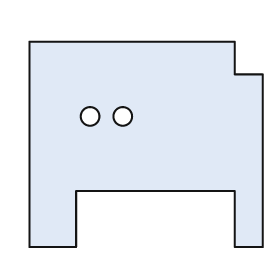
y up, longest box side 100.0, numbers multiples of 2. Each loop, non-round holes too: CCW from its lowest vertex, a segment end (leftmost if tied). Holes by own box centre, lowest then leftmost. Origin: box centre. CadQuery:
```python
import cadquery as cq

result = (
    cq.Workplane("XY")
    .moveTo(-50.0, -44.0)
    .lineTo(-30.0, -44.0)
    .lineTo(-30.0, -20.0)
    .lineTo(38.0, -20.0)
    .lineTo(38.0, -44.0)
    .lineTo(50.0, -44.0)
    .lineTo(50.0, 30.0)
    .lineTo(38.0, 30.0)
    .lineTo(38.0, 44.0)
    .lineTo(-50.0, 44.0)
    .close()
    .moveTo(-24.0, 12.0)
    .circle(4.0)
    .moveTo(-10.0, 12.0)
    .circle(4.0)
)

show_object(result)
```